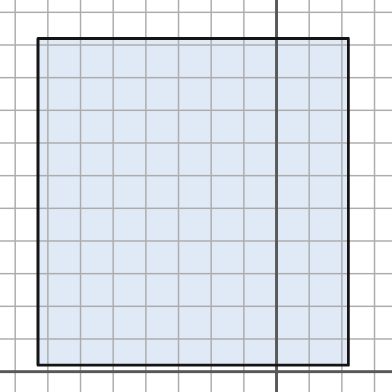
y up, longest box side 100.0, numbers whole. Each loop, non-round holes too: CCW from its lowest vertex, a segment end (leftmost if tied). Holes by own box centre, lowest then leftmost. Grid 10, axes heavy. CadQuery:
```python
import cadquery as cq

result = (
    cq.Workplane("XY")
    .moveTo(-73.0, 2.0)
    .lineTo(22.0, 2.0)
    .lineTo(22.0, 102.0)
    .lineTo(-73.0, 102.0)
    .close()
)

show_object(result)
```